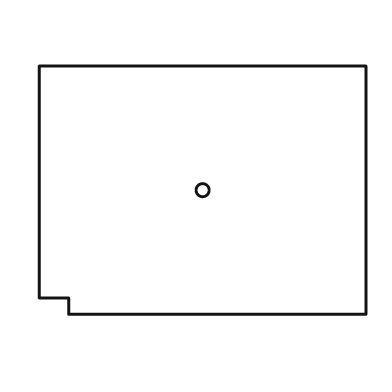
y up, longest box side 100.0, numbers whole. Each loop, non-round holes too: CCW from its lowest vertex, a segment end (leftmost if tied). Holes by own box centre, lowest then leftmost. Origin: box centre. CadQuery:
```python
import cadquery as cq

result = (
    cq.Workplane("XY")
    .moveTo(-41.0, -38.0)
    .lineTo(50.0, -38.0)
    .lineTo(50.0, 38.0)
    .lineTo(-50.0, 38.0)
    .lineTo(-50.0, -33.0)
    .lineTo(-41.0, -33.0)
    .close()
    .moveTo(0.0, 0.0)
    .circle(2.0)
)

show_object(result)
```